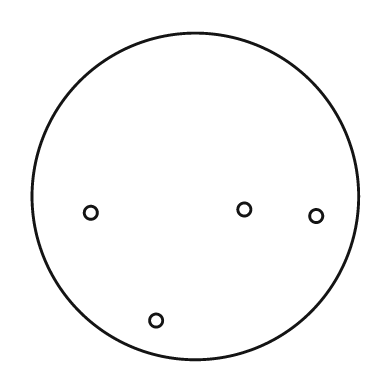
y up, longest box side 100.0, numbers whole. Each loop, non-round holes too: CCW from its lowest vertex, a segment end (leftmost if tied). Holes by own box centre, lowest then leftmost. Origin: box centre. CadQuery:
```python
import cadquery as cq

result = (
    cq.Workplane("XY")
    .moveTo(0.0, 0.0)
    .circle(50.0)
    .moveTo(-12.0, -38.0)
    .circle(2.0)
    .moveTo(37.0, -6.0)
    .circle(2.0)
    .moveTo(-32.0, -5.0)
    .circle(2.0)
    .moveTo(15.0, -4.0)
    .circle(2.0)
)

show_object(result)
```